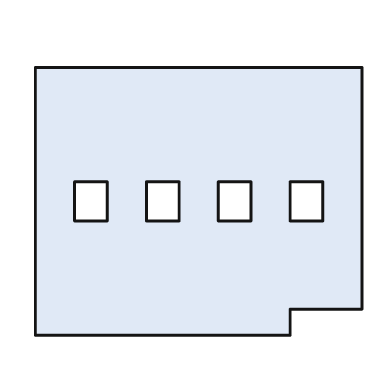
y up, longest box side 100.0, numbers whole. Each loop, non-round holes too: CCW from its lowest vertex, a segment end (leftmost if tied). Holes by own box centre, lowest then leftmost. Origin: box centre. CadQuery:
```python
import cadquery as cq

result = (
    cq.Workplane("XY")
    .moveTo(-50.0, -41.0)
    .lineTo(28.0, -41.0)
    .lineTo(28.0, -33.0)
    .lineTo(50.0, -33.0)
    .lineTo(50.0, 41.0)
    .lineTo(-50.0, 41.0)
    .close()
    .moveTo(-38.0, -6.0)
    .lineTo(-28.0, -6.0)
    .lineTo(-28.0, 6.0)
    .lineTo(-38.0, 6.0)
    .close()
    .moveTo(-16.0, -6.0)
    .lineTo(-6.0, -6.0)
    .lineTo(-6.0, 6.0)
    .lineTo(-16.0, 6.0)
    .close()
    .moveTo(6.0, -6.0)
    .lineTo(16.0, -6.0)
    .lineTo(16.0, 6.0)
    .lineTo(6.0, 6.0)
    .close()
    .moveTo(28.0, -6.0)
    .lineTo(38.0, -6.0)
    .lineTo(38.0, 6.0)
    .lineTo(28.0, 6.0)
    .close()
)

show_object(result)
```